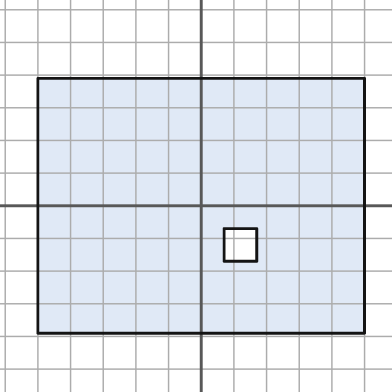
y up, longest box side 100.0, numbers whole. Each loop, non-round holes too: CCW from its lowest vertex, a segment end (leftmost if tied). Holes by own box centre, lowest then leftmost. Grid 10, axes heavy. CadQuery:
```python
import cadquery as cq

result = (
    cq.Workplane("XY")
    .moveTo(-50.0, -39.0)
    .lineTo(50.0, -39.0)
    .lineTo(50.0, 39.0)
    .lineTo(-50.0, 39.0)
    .close()
    .moveTo(7.0, -17.0)
    .lineTo(17.0, -17.0)
    .lineTo(17.0, -7.0)
    .lineTo(7.0, -7.0)
    .close()
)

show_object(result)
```